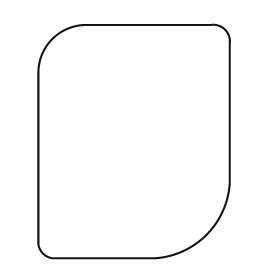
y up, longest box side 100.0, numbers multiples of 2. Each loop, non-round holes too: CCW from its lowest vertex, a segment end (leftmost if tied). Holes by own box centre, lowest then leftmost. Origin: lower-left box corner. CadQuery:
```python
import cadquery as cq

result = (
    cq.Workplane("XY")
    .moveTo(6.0, 0.0)
    .lineTo(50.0, 0.0)
    .threePointArc((72.0, 10.0), (82.0, 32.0))
    .lineTo(82.0, 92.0)
    .threePointArc((80.0, 98.0), (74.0, 100.0))
    .lineTo(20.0, 100.0)
    .threePointArc((6.0, 94.0), (0.0, 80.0))
    .lineTo(0.0, 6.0)
    .threePointArc((2.0, 2.0), (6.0, 0.0))
    .close()
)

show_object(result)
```